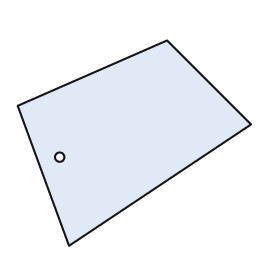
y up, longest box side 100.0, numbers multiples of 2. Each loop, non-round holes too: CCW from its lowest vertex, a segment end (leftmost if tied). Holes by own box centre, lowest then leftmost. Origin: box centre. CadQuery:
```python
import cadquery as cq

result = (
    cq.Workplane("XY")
    .moveTo(-28.0, -44.0)
    .lineTo(50.0, 8.0)
    .lineTo(14.0, 44.0)
    .lineTo(-50.0, 16.0)
    .close()
    .moveTo(-32.0, -6.0)
    .circle(2.0)
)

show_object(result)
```